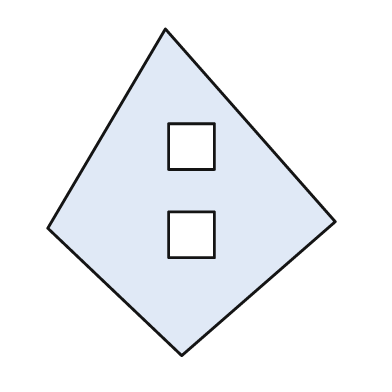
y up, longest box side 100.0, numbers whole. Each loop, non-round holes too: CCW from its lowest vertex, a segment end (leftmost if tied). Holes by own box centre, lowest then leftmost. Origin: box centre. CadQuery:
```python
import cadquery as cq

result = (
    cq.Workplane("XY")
    .moveTo(-3.0, -50.0)
    .lineTo(44.0, -9.0)
    .lineTo(-8.0, 50.0)
    .lineTo(-44.0, -11.0)
    .close()
    .moveTo(-7.0, -20.0)
    .lineTo(7.0, -20.0)
    .lineTo(7.0, -6.0)
    .lineTo(-7.0, -6.0)
    .close()
    .moveTo(-7.0, 7.0)
    .lineTo(7.0, 7.0)
    .lineTo(7.0, 21.0)
    .lineTo(-7.0, 21.0)
    .close()
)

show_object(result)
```